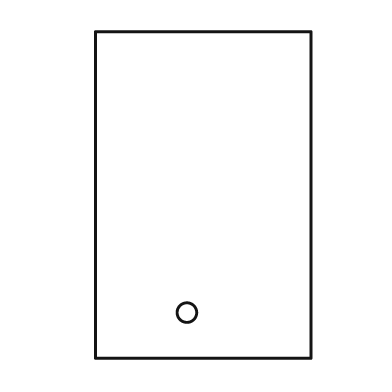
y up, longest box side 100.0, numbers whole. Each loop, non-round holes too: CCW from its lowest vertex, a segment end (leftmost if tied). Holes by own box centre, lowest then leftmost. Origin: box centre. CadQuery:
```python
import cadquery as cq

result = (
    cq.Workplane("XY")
    .moveTo(-33.0, -50.0)
    .lineTo(33.0, -50.0)
    .lineTo(33.0, 50.0)
    .lineTo(-33.0, 50.0)
    .close()
    .moveTo(-5.0, -36.0)
    .circle(3.0)
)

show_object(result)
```